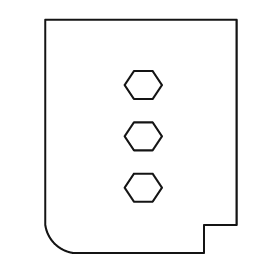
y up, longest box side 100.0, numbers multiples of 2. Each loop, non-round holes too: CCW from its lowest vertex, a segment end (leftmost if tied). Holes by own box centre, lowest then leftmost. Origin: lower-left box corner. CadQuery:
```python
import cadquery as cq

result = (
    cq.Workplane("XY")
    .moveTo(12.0, 0.0)
    .lineTo(68.0, 0.0)
    .lineTo(68.0, 12.0)
    .lineTo(82.0, 12.0)
    .lineTo(82.0, 100.0)
    .lineTo(0.0, 100.0)
    .lineTo(0.0, 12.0)
    .threePointArc((4.0, 4.0), (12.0, 0.0))
    .close()
    .moveTo(38.0, 22.0)
    .lineTo(46.0, 22.0)
    .lineTo(50.0, 28.0)
    .lineTo(46.0, 34.0)
    .lineTo(38.0, 34.0)
    .lineTo(34.0, 28.0)
    .close()
    .moveTo(38.0, 44.0)
    .lineTo(46.0, 44.0)
    .lineTo(50.0, 50.0)
    .lineTo(46.0, 56.0)
    .lineTo(38.0, 56.0)
    .lineTo(34.0, 50.0)
    .close()
    .moveTo(38.0, 66.0)
    .lineTo(46.0, 66.0)
    .lineTo(50.0, 72.0)
    .lineTo(46.0, 78.0)
    .lineTo(38.0, 78.0)
    .lineTo(34.0, 72.0)
    .close()
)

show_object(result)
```